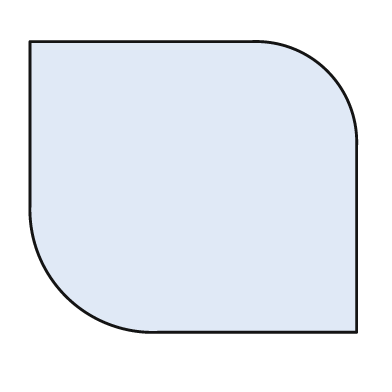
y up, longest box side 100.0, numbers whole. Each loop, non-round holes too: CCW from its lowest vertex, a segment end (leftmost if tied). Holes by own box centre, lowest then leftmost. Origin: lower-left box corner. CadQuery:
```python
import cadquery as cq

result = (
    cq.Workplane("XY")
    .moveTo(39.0, 0.0)
    .lineTo(100.0, 0.0)
    .lineTo(100.0, 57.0)
    .threePointArc((91.0, 80.0), (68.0, 89.0))
    .lineTo(0.0, 89.0)
    .lineTo(0.0, 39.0)
    .threePointArc((11.0, 11.0), (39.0, 0.0))
    .close()
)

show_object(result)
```